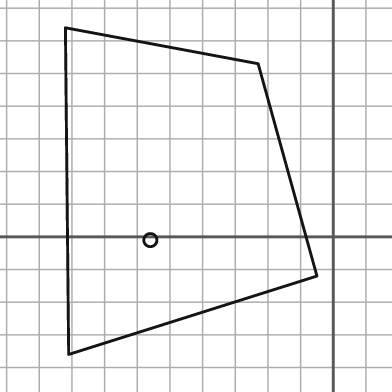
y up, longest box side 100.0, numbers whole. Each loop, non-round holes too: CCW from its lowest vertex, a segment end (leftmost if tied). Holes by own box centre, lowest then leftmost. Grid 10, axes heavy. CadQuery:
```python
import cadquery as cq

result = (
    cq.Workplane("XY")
    .moveTo(-81.0, -36.0)
    .lineTo(-5.0, -12.0)
    .lineTo(-23.0, 53.0)
    .lineTo(-82.0, 64.0)
    .close()
    .moveTo(-56.0, -1.0)
    .circle(2.0)
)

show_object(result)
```